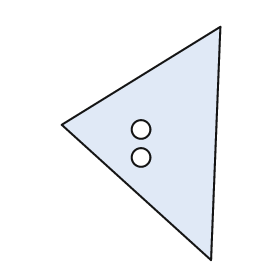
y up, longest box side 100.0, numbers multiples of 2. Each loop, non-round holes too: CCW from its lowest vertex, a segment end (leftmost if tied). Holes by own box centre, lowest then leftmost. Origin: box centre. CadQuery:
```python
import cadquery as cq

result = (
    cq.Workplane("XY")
    .moveTo(30.0, -50.0)
    .lineTo(34.0, 50.0)
    .lineTo(-34.0, 8.0)
    .close()
    .moveTo(0.0, -6.0)
    .circle(4.0)
    .moveTo(0.0, 6.0)
    .circle(4.0)
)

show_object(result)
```